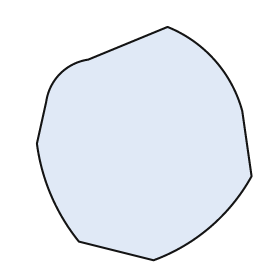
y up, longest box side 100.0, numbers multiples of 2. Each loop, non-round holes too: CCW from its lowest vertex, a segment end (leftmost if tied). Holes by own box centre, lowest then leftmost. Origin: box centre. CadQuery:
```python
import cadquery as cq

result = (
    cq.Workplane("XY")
    .moveTo(4.0, -50.0)
    .threePointArc((28.0, -36.0), (46.0, -14.0))
    .lineTo(42.0, 14.0)
    .threePointArc((30.0, 36.0), (10.0, 50.0))
    .lineTo(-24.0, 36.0)
    .threePointArc((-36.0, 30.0), (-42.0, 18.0))
    .lineTo(-46.0, 0.0)
    .threePointArc((-40.0, -22.0), (-28.0, -42.0))
    .close()
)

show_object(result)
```